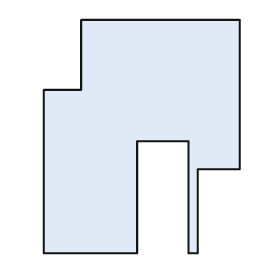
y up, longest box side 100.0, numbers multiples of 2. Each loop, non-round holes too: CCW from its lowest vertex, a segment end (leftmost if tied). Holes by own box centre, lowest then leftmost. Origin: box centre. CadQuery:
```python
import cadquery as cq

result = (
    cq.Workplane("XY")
    .moveTo(-42.0, -50.0)
    .lineTo(-2.0, -50.0)
    .lineTo(-2.0, -2.0)
    .lineTo(20.0, -2.0)
    .lineTo(20.0, -50.0)
    .lineTo(24.0, -50.0)
    .lineTo(24.0, -14.0)
    .lineTo(42.0, -14.0)
    .lineTo(42.0, 50.0)
    .lineTo(-26.0, 50.0)
    .lineTo(-26.0, 20.0)
    .lineTo(-42.0, 20.0)
    .close()
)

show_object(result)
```